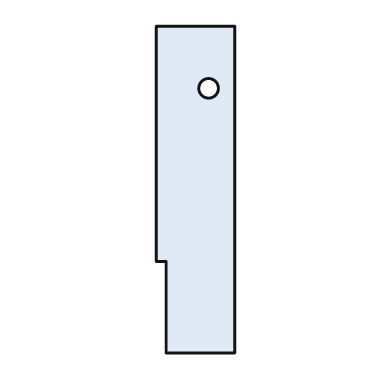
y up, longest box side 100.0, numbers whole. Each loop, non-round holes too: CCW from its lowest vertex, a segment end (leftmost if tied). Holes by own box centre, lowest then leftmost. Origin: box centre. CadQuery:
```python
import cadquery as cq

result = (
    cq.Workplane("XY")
    .moveTo(-9.0, -50.0)
    .lineTo(12.0, -50.0)
    .lineTo(12.0, 50.0)
    .lineTo(-12.0, 50.0)
    .lineTo(-12.0, -22.0)
    .lineTo(-9.0, -22.0)
    .close()
    .moveTo(4.0, 31.0)
    .circle(3.0)
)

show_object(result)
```